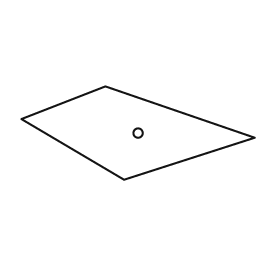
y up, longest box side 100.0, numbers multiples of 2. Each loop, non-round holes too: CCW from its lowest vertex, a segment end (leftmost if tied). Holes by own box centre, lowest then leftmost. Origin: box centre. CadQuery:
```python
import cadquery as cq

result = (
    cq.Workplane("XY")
    .moveTo(-6.0, -20.0)
    .lineTo(50.0, -2.0)
    .lineTo(-14.0, 20.0)
    .lineTo(-50.0, 6.0)
    .close()
    .moveTo(0.0, 0.0)
    .circle(2.0)
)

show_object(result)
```